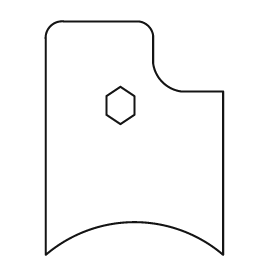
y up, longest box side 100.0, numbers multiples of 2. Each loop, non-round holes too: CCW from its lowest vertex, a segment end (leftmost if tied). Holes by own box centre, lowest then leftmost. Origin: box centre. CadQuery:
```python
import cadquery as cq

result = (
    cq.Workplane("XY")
    .moveTo(-38.0, -50.0)
    .threePointArc((0.0, -36.0), (38.0, -50.0))
    .lineTo(38.0, 20.0)
    .lineTo(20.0, 20.0)
    .threePointArc((12.0, 24.0), (8.0, 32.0))
    .lineTo(8.0, 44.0)
    .threePointArc((6.0, 48.0), (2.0, 50.0))
    .lineTo(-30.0, 50.0)
    .threePointArc((-36.0, 48.0), (-38.0, 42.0))
    .close()
    .moveTo(-6.0, 6.0)
    .lineTo(0.0, 10.0)
    .lineTo(0.0, 18.0)
    .lineTo(-6.0, 22.0)
    .lineTo(-12.0, 18.0)
    .lineTo(-12.0, 10.0)
    .close()
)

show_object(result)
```